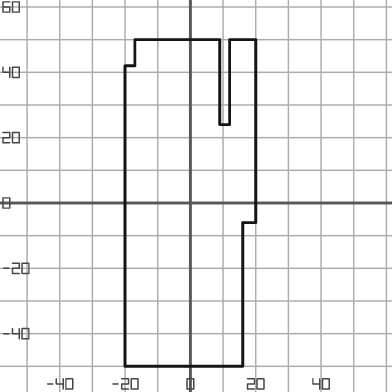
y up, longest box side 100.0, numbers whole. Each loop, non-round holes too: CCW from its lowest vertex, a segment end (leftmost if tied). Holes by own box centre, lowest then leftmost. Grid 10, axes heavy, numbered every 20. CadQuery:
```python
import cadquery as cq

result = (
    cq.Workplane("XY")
    .moveTo(-20.0, -50.0)
    .lineTo(16.0, -50.0)
    .lineTo(16.0, -6.0)
    .lineTo(20.0, -6.0)
    .lineTo(20.0, 50.0)
    .lineTo(12.0, 50.0)
    .lineTo(12.0, 24.0)
    .lineTo(9.0, 24.0)
    .lineTo(9.0, 50.0)
    .lineTo(-17.0, 50.0)
    .lineTo(-17.0, 42.0)
    .lineTo(-20.0, 42.0)
    .close()
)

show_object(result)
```